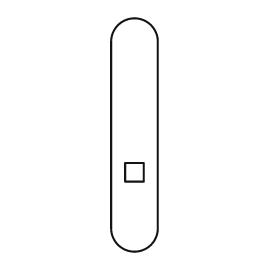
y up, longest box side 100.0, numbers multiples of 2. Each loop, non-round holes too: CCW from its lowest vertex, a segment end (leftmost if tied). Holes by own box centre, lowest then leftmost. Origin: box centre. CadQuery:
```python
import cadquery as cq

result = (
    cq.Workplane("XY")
    .moveTo(-10.0, -40.0)
    .threePointArc((0.0, -50.0), (10.0, -40.0))
    .lineTo(10.0, 40.0)
    .threePointArc((0.0, 50.0), (-10.0, 40.0))
    .close()
    .moveTo(-4.0, -20.0)
    .lineTo(4.0, -20.0)
    .lineTo(4.0, -12.0)
    .lineTo(-4.0, -12.0)
    .close()
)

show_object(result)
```